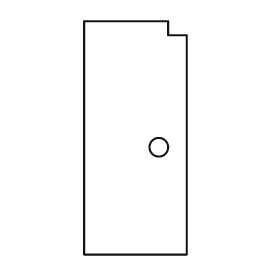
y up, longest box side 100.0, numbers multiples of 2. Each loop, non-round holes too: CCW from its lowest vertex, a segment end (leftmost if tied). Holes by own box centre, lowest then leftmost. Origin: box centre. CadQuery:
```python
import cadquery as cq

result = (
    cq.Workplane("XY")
    .moveTo(-22.0, -50.0)
    .lineTo(22.0, -50.0)
    .lineTo(22.0, 44.0)
    .lineTo(14.0, 44.0)
    .lineTo(14.0, 50.0)
    .lineTo(-22.0, 50.0)
    .close()
    .moveTo(10.0, -4.0)
    .circle(4.0)
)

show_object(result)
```